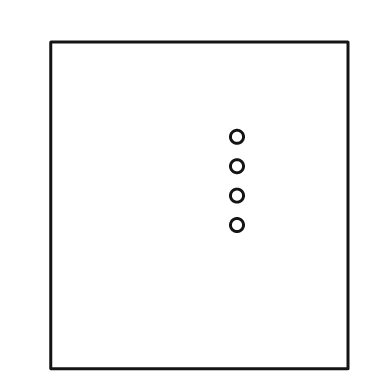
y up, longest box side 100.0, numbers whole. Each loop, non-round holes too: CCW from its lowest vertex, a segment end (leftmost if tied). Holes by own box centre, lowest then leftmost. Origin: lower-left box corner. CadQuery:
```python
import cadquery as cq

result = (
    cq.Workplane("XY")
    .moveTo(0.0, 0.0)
    .lineTo(91.0, 0.0)
    .lineTo(91.0, 100.0)
    .lineTo(0.0, 100.0)
    .close()
    .moveTo(57.0, 44.0)
    .circle(2.0)
    .moveTo(57.0, 53.0)
    .circle(2.0)
    .moveTo(57.0, 62.0)
    .circle(2.0)
    .moveTo(57.0, 71.0)
    .circle(2.0)
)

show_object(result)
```